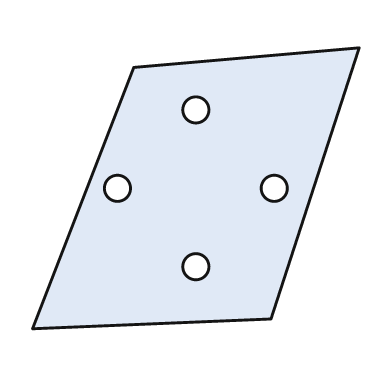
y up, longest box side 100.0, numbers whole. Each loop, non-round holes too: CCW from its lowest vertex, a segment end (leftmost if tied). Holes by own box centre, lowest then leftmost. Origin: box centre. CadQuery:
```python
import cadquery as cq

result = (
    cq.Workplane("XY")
    .moveTo(-50.0, -43.0)
    .lineTo(23.0, -40.0)
    .lineTo(50.0, 43.0)
    .lineTo(-19.0, 37.0)
    .close()
    .moveTo(0.0, -24.0)
    .circle(4.0)
    .moveTo(-24.0, 0.0)
    .circle(4.0)
    .moveTo(24.0, 0.0)
    .circle(4.0)
    .moveTo(0.0, 24.0)
    .circle(4.0)
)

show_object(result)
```